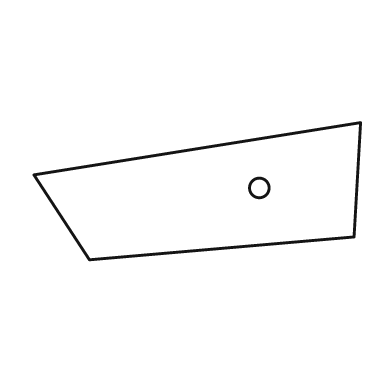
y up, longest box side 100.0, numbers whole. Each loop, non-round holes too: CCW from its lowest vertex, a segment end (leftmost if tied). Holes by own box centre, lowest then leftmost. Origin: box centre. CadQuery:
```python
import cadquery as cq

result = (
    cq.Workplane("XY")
    .moveTo(-33.0, -21.0)
    .lineTo(48.0, -14.0)
    .lineTo(50.0, 21.0)
    .lineTo(-50.0, 5.0)
    .close()
    .moveTo(19.0, 1.0)
    .circle(3.0)
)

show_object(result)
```